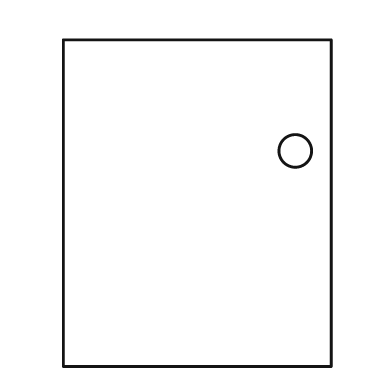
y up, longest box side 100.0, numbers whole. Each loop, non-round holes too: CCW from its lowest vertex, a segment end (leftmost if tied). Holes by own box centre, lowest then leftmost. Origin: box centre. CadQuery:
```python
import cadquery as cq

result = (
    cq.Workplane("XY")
    .moveTo(-41.0, -50.0)
    .lineTo(41.0, -50.0)
    .lineTo(41.0, 50.0)
    .lineTo(-41.0, 50.0)
    .close()
    .moveTo(30.0, 16.0)
    .circle(5.0)
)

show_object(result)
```